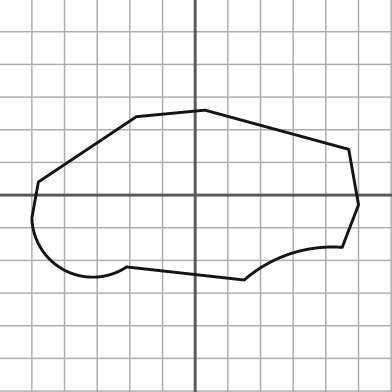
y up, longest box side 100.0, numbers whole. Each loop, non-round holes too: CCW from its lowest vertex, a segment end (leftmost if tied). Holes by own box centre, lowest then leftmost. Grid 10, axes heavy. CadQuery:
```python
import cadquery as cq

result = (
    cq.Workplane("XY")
    .moveTo(15.0, -26.0)
    .threePointArc((29.0, -18.0), (45.0, -16.0))
    .lineTo(50.0, -3.0)
    .lineTo(47.0, 14.0)
    .lineTo(3.0, 26.0)
    .lineTo(-18.0, 24.0)
    .lineTo(-48.0, 4.0)
    .lineTo(-50.0, -7.0)
    .threePointArc((-40.0, -23.0), (-21.0, -22.0))
    .close()
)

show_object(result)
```